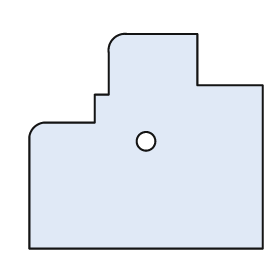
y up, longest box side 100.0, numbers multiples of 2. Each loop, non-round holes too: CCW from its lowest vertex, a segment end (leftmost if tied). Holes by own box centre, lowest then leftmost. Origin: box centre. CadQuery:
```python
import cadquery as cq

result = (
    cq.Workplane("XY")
    .moveTo(-50.0, -46.0)
    .lineTo(50.0, -46.0)
    .lineTo(50.0, 24.0)
    .lineTo(22.0, 24.0)
    .lineTo(22.0, 46.0)
    .lineTo(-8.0, 46.0)
    .threePointArc((-14.0, 44.0), (-16.0, 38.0))
    .lineTo(-16.0, 20.0)
    .lineTo(-22.0, 20.0)
    .lineTo(-22.0, 8.0)
    .lineTo(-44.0, 8.0)
    .threePointArc((-48.0, 6.0), (-50.0, 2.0))
    .close()
    .moveTo(0.0, 0.0)
    .circle(4.0)
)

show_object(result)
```